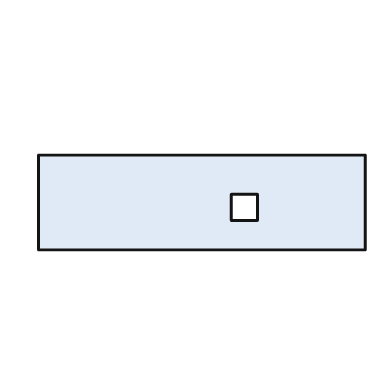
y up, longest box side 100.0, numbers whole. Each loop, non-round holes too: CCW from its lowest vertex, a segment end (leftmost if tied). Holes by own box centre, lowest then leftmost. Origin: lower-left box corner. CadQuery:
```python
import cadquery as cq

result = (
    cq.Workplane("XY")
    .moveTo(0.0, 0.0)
    .lineTo(100.0, 0.0)
    .lineTo(100.0, 29.0)
    .lineTo(0.0, 29.0)
    .close()
    .moveTo(59.0, 9.0)
    .lineTo(67.0, 9.0)
    .lineTo(67.0, 17.0)
    .lineTo(59.0, 17.0)
    .close()
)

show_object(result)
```